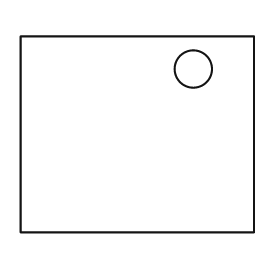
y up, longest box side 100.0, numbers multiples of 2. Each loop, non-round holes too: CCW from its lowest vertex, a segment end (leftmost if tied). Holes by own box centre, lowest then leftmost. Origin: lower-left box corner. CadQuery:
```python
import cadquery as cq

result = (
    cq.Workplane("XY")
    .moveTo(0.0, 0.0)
    .lineTo(100.0, 0.0)
    .lineTo(100.0, 84.0)
    .lineTo(0.0, 84.0)
    .close()
    .moveTo(74.0, 70.0)
    .circle(8.0)
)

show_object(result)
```